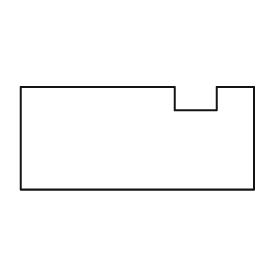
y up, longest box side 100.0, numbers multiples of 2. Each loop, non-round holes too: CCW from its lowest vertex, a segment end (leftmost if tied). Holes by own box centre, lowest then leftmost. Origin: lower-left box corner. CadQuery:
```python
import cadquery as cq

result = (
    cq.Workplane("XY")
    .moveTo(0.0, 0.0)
    .lineTo(100.0, 0.0)
    .lineTo(100.0, 44.0)
    .lineTo(84.0, 44.0)
    .lineTo(84.0, 34.0)
    .lineTo(66.0, 34.0)
    .lineTo(66.0, 44.0)
    .lineTo(0.0, 44.0)
    .close()
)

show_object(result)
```